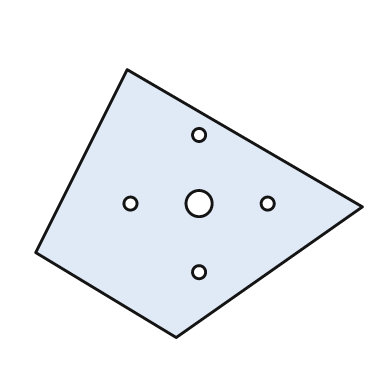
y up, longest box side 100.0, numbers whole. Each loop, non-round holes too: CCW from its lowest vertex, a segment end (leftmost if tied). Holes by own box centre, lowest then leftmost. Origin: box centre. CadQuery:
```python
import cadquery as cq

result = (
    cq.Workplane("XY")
    .moveTo(-7.0, -41.0)
    .lineTo(50.0, -1.0)
    .lineTo(-22.0, 41.0)
    .lineTo(-50.0, -15.0)
    .close()
    .moveTo(0.0, -21.0)
    .circle(2.0)
    .moveTo(-21.0, 0.0)
    .circle(2.0)
    .moveTo(0.0, 0.0)
    .circle(4.0)
    .moveTo(21.0, 0.0)
    .circle(2.0)
    .moveTo(0.0, 21.0)
    .circle(2.0)
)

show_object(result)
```